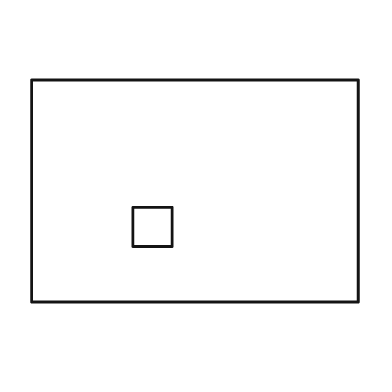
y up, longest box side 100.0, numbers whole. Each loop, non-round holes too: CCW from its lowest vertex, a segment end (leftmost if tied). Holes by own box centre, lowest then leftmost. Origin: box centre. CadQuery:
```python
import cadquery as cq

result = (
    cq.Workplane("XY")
    .moveTo(-50.0, -34.0)
    .lineTo(50.0, -34.0)
    .lineTo(50.0, 34.0)
    .lineTo(-50.0, 34.0)
    .close()
    .moveTo(-19.0, -17.0)
    .lineTo(-7.0, -17.0)
    .lineTo(-7.0, -5.0)
    .lineTo(-19.0, -5.0)
    .close()
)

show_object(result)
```